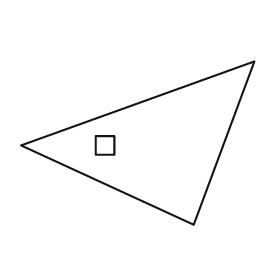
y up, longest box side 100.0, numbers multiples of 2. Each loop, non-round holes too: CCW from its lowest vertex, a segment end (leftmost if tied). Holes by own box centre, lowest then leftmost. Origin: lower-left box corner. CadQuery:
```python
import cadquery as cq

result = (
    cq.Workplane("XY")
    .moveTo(74.0, 0.0)
    .lineTo(100.0, 70.0)
    .lineTo(0.0, 34.0)
    .close()
    .moveTo(32.0, 30.0)
    .lineTo(40.0, 30.0)
    .lineTo(40.0, 38.0)
    .lineTo(32.0, 38.0)
    .close()
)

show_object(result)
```